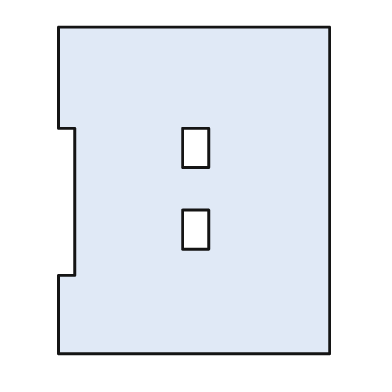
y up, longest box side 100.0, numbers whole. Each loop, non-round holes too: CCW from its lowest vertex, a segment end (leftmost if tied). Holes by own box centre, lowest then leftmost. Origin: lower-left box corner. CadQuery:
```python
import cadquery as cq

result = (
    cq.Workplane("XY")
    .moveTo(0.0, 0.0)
    .lineTo(83.0, 0.0)
    .lineTo(83.0, 100.0)
    .lineTo(0.0, 100.0)
    .lineTo(0.0, 69.0)
    .lineTo(5.0, 69.0)
    .lineTo(5.0, 24.0)
    .lineTo(0.0, 24.0)
    .close()
    .moveTo(38.0, 32.0)
    .lineTo(46.0, 32.0)
    .lineTo(46.0, 44.0)
    .lineTo(38.0, 44.0)
    .close()
    .moveTo(38.0, 57.0)
    .lineTo(46.0, 57.0)
    .lineTo(46.0, 69.0)
    .lineTo(38.0, 69.0)
    .close()
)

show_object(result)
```